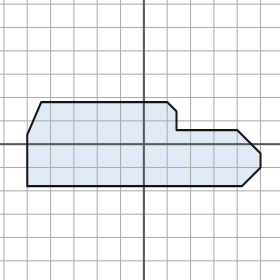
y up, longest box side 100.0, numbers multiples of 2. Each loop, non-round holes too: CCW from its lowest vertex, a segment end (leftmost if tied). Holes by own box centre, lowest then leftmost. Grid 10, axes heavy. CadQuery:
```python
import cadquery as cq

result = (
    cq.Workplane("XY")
    .moveTo(-50.0, -18.0)
    .lineTo(42.0, -18.0)
    .lineTo(50.0, -10.0)
    .lineTo(50.0, -4.0)
    .lineTo(40.0, 6.0)
    .lineTo(14.0, 6.0)
    .lineTo(14.0, 14.0)
    .lineTo(10.0, 18.0)
    .lineTo(-44.0, 18.0)
    .lineTo(-50.0, 4.0)
    .close()
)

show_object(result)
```